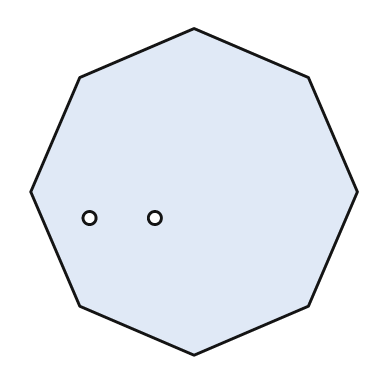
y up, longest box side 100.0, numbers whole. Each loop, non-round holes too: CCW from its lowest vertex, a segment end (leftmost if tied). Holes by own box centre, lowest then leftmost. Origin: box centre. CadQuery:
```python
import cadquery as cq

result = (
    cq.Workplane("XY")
    .moveTo(0.0, -50.0)
    .lineTo(35.0, -35.0)
    .lineTo(50.0, 0.0)
    .lineTo(35.0, 35.0)
    .lineTo(0.0, 50.0)
    .lineTo(-35.0, 35.0)
    .lineTo(-50.0, 0.0)
    .lineTo(-35.0, -35.0)
    .close()
    .moveTo(-32.0, -8.0)
    .circle(2.0)
    .moveTo(-12.0, -8.0)
    .circle(2.0)
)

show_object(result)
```